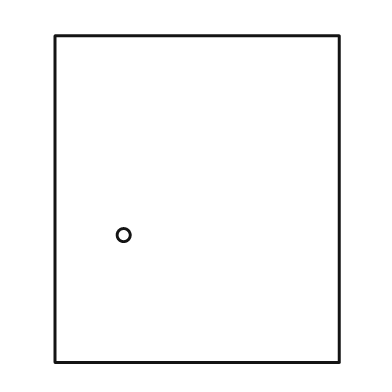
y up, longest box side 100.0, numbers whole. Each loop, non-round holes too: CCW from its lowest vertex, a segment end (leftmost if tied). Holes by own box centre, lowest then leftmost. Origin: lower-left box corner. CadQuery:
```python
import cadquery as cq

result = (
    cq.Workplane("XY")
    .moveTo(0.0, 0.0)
    .lineTo(87.0, 0.0)
    .lineTo(87.0, 100.0)
    .lineTo(0.0, 100.0)
    .close()
    .moveTo(21.0, 39.0)
    .circle(2.0)
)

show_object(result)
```